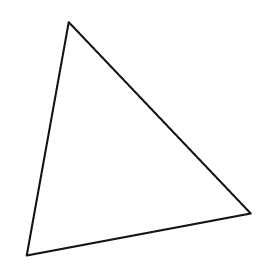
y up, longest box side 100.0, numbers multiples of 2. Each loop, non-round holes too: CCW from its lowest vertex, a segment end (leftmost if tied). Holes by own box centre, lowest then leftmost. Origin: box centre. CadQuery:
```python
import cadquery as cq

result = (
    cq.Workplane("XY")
    .moveTo(-48.0, -50.0)
    .lineTo(48.0, -32.0)
    .lineTo(-30.0, 50.0)
    .close()
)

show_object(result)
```